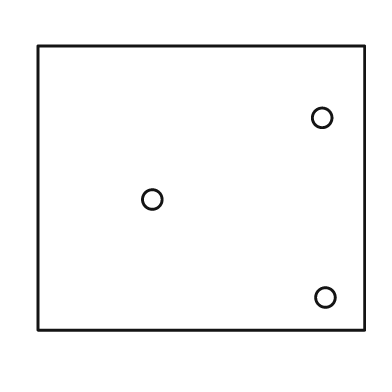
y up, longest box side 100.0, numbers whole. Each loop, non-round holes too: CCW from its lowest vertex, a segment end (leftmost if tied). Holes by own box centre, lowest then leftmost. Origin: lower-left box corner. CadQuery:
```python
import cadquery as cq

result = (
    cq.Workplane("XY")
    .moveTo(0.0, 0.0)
    .lineTo(100.0, 0.0)
    .lineTo(100.0, 87.0)
    .lineTo(0.0, 87.0)
    .close()
    .moveTo(88.0, 10.0)
    .circle(3.0)
    .moveTo(35.0, 40.0)
    .circle(3.0)
    .moveTo(87.0, 65.0)
    .circle(3.0)
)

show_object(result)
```